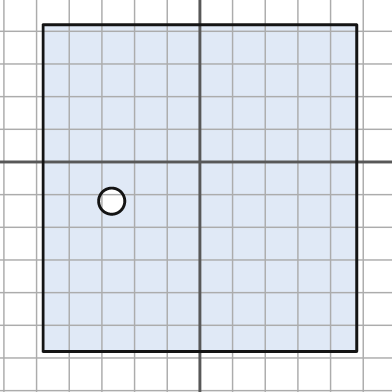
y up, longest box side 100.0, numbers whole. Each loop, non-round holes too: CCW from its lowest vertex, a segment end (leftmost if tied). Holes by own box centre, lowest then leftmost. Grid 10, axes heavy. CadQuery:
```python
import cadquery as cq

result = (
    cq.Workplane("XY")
    .moveTo(-48.0, -58.0)
    .lineTo(48.0, -58.0)
    .lineTo(48.0, 42.0)
    .lineTo(-48.0, 42.0)
    .close()
    .moveTo(-27.0, -12.0)
    .circle(4.0)
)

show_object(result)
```